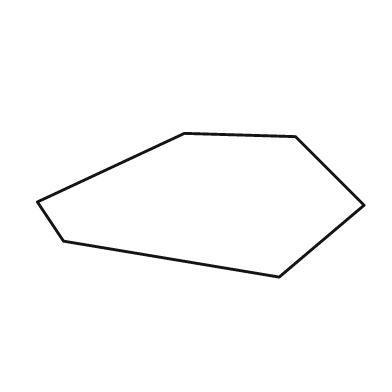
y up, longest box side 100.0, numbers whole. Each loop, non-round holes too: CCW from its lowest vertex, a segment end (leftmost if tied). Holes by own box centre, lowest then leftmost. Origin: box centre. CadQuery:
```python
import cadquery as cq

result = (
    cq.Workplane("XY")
    .moveTo(24.0, -22.0)
    .lineTo(50.0, 0.0)
    .lineTo(29.0, 21.0)
    .lineTo(-5.0, 22.0)
    .lineTo(-50.0, 1.0)
    .lineTo(-42.0, -11.0)
    .close()
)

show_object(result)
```